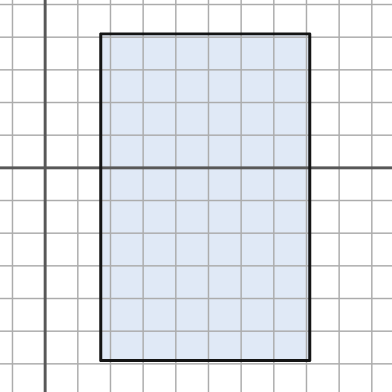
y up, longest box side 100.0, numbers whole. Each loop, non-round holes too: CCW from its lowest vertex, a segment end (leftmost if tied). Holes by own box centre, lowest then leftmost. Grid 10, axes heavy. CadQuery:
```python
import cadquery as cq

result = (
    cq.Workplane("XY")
    .moveTo(17.0, -59.0)
    .lineTo(81.0, -59.0)
    .lineTo(81.0, 41.0)
    .lineTo(17.0, 41.0)
    .close()
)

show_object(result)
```